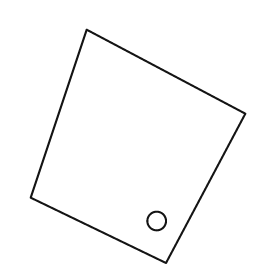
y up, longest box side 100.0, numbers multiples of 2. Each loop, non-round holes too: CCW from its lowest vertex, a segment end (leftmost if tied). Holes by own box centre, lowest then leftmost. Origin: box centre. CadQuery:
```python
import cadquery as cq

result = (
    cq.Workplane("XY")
    .moveTo(12.0, -50.0)
    .lineTo(46.0, 14.0)
    .lineTo(-22.0, 50.0)
    .lineTo(-46.0, -22.0)
    .close()
    .moveTo(8.0, -32.0)
    .circle(4.0)
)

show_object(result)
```